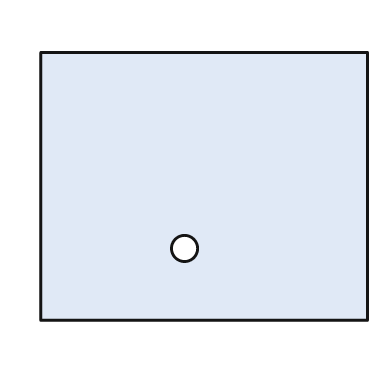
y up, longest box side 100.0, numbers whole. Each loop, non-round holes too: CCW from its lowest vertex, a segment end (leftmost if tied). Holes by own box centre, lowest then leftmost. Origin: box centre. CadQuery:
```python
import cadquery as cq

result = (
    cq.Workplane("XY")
    .moveTo(-50.0, -41.0)
    .lineTo(50.0, -41.0)
    .lineTo(50.0, 41.0)
    .lineTo(-50.0, 41.0)
    .close()
    .moveTo(-6.0, -19.0)
    .circle(4.0)
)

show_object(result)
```